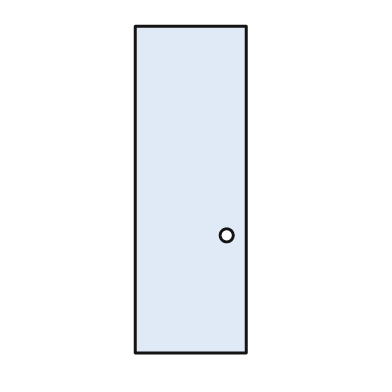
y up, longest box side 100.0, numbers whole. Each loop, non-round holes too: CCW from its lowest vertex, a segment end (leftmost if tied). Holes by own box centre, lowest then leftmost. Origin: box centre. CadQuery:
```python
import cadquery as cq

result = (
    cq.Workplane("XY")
    .moveTo(-17.0, -50.0)
    .lineTo(17.0, -50.0)
    .lineTo(17.0, 50.0)
    .lineTo(-17.0, 50.0)
    .close()
    .moveTo(11.0, -14.0)
    .circle(2.0)
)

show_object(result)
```